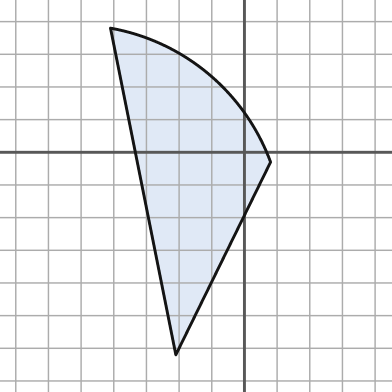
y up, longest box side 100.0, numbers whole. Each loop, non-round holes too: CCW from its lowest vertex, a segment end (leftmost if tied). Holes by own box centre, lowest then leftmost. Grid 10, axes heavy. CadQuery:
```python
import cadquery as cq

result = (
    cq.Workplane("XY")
    .moveTo(-21.0, -62.0)
    .lineTo(8.0, -3.0)
    .threePointArc((-11.0, 24.0), (-41.0, 38.0))
    .close()
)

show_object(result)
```